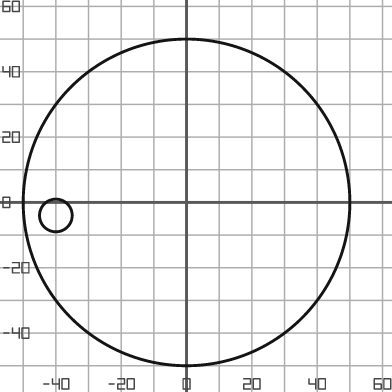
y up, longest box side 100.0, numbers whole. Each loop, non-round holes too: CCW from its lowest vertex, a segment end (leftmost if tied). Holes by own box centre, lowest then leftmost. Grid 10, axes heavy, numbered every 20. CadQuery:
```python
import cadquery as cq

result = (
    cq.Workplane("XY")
    .moveTo(0.0, 0.0)
    .circle(50.0)
    .moveTo(-40.0, -4.0)
    .circle(5.0)
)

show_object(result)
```